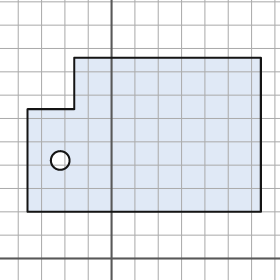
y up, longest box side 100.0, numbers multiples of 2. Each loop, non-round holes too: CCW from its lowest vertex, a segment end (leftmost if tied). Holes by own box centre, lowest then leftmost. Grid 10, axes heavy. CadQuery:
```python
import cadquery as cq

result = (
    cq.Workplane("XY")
    .moveTo(-36.0, 20.0)
    .lineTo(64.0, 20.0)
    .lineTo(64.0, 86.0)
    .lineTo(-16.0, 86.0)
    .lineTo(-16.0, 64.0)
    .lineTo(-36.0, 64.0)
    .close()
    .moveTo(-22.0, 42.0)
    .circle(4.0)
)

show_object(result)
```